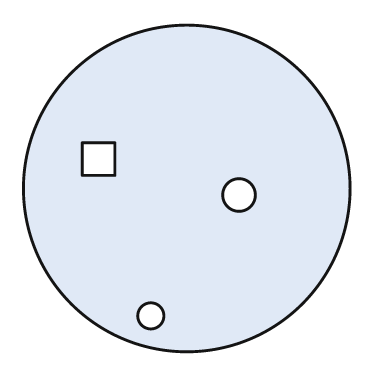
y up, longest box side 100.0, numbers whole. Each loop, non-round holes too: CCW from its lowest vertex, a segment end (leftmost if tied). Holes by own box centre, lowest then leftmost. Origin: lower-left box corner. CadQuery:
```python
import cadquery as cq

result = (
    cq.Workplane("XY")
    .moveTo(50.0, 50.0)
    .circle(50.0)
    .moveTo(39.0, 11.0)
    .circle(4.0)
    .moveTo(66.0, 48.0)
    .circle(5.0)
    .moveTo(18.0, 54.0)
    .lineTo(28.0, 54.0)
    .lineTo(28.0, 64.0)
    .lineTo(18.0, 64.0)
    .close()
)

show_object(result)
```